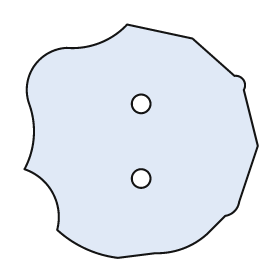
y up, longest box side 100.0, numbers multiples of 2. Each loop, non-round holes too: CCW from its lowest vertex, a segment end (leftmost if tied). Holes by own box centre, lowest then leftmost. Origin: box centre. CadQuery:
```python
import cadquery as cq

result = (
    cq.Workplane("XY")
    .moveTo(-10.0, -50.0)
    .lineTo(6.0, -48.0)
    .threePointArc((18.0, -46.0), (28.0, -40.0))
    .lineTo(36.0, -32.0)
    .threePointArc((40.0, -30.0), (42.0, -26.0))
    .lineTo(50.0, -2.0)
    .lineTo(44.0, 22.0)
    .threePointArc((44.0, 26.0), (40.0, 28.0))
    .lineTo(22.0, 44.0)
    .lineTo(-6.0, 50.0)
    .threePointArc((-18.0, 42.0), (-32.0, 40.0))
    .threePointArc((-46.0, 32.0), (-48.0, 16.0))
    .threePointArc((-46.0, 2.0), (-50.0, -12.0))
    .threePointArc((-38.0, -22.0), (-36.0, -38.0))
    .threePointArc((-24.0, -46.0), (-10.0, -50.0))
    .close()
    .moveTo(0.0, -16.0)
    .circle(4.0)
    .moveTo(0.0, 16.0)
    .circle(4.0)
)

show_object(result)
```